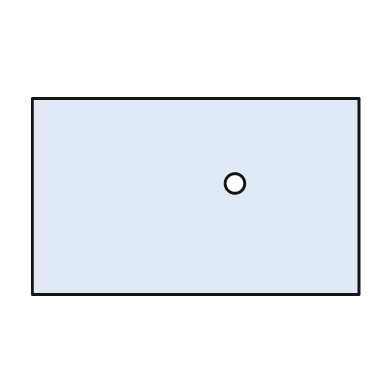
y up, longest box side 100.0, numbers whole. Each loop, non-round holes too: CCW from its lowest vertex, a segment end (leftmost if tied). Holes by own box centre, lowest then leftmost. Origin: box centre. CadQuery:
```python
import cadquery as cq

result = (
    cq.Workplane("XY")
    .moveTo(-50.0, -30.0)
    .lineTo(50.0, -30.0)
    .lineTo(50.0, 30.0)
    .lineTo(-50.0, 30.0)
    .close()
    .moveTo(12.0, 4.0)
    .circle(3.0)
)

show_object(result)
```